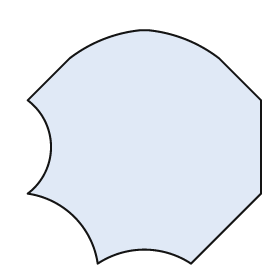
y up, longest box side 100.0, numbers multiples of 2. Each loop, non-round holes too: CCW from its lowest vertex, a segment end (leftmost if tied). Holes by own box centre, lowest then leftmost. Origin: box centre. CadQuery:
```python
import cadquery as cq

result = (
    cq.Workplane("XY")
    .moveTo(-20.0, -50.0)
    .threePointArc((0.0, -44.0), (20.0, -50.0))
    .lineTo(50.0, -20.0)
    .lineTo(50.0, 20.0)
    .lineTo(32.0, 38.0)
    .threePointArc((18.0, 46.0), (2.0, 50.0))
    .lineTo(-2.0, 50.0)
    .threePointArc((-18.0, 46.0), (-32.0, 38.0))
    .lineTo(-50.0, 20.0)
    .threePointArc((-40.0, 0.0), (-50.0, -20.0))
    .threePointArc((-30.0, -30.0), (-20.0, -50.0))
    .close()
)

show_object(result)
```